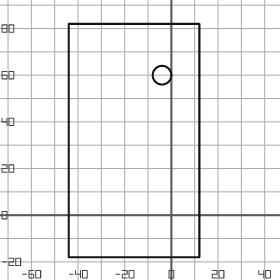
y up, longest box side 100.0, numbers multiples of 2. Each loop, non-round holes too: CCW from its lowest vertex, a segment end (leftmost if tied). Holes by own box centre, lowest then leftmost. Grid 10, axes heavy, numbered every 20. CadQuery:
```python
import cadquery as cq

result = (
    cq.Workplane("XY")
    .moveTo(-44.0, -18.0)
    .lineTo(12.0, -18.0)
    .lineTo(12.0, 82.0)
    .lineTo(-44.0, 82.0)
    .close()
    .moveTo(-4.0, 60.0)
    .circle(4.0)
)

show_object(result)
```